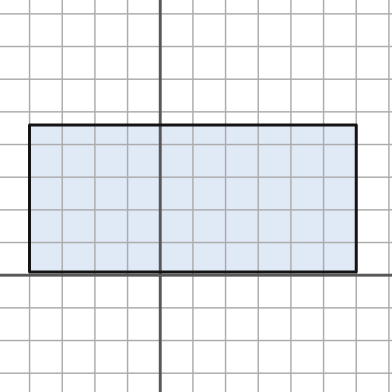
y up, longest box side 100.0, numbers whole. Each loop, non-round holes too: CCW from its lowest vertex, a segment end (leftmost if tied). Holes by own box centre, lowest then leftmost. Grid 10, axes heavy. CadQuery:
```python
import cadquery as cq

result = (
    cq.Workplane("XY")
    .moveTo(-40.0, 1.0)
    .lineTo(60.0, 1.0)
    .lineTo(60.0, 46.0)
    .lineTo(-40.0, 46.0)
    .close()
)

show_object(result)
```